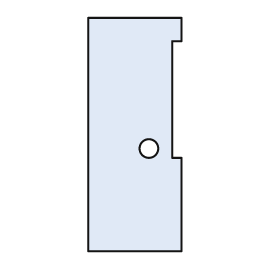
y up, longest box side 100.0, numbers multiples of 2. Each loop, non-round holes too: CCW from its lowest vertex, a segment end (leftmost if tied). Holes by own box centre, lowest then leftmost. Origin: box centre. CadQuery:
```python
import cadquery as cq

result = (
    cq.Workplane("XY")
    .moveTo(-20.0, -50.0)
    .lineTo(20.0, -50.0)
    .lineTo(20.0, -10.0)
    .lineTo(16.0, -10.0)
    .lineTo(16.0, 40.0)
    .lineTo(20.0, 40.0)
    .lineTo(20.0, 50.0)
    .lineTo(-20.0, 50.0)
    .close()
    .moveTo(6.0, -6.0)
    .circle(4.0)
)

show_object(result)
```